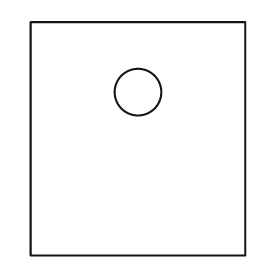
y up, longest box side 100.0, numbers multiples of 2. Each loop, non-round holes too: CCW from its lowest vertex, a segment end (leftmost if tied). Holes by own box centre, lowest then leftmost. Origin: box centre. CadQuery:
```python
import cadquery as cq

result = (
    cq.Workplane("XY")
    .moveTo(-46.0, -50.0)
    .lineTo(46.0, -50.0)
    .lineTo(46.0, 50.0)
    .lineTo(-46.0, 50.0)
    .close()
    .moveTo(0.0, 20.0)
    .circle(10.0)
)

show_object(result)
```